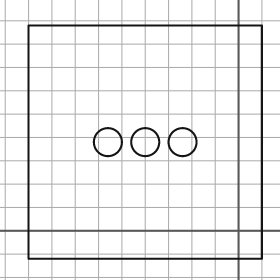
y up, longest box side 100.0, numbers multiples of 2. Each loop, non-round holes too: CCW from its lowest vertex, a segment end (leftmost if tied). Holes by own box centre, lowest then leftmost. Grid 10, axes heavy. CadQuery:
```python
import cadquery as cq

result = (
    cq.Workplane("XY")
    .moveTo(-90.0, -12.0)
    .lineTo(10.0, -12.0)
    .lineTo(10.0, 88.0)
    .lineTo(-90.0, 88.0)
    .close()
    .moveTo(-56.0, 38.0)
    .circle(6.0)
    .moveTo(-40.0, 38.0)
    .circle(6.0)
    .moveTo(-24.0, 38.0)
    .circle(6.0)
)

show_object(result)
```